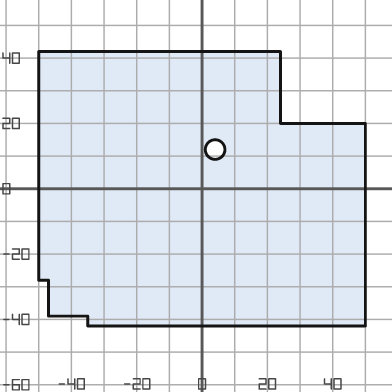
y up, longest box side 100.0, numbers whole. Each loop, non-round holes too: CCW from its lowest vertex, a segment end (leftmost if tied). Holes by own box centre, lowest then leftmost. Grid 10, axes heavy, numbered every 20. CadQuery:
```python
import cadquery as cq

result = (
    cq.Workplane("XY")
    .moveTo(-35.0, -42.0)
    .lineTo(50.0, -42.0)
    .lineTo(50.0, 20.0)
    .lineTo(24.0, 20.0)
    .lineTo(24.0, 42.0)
    .lineTo(-50.0, 42.0)
    .lineTo(-50.0, -28.0)
    .lineTo(-47.0, -28.0)
    .lineTo(-47.0, -39.0)
    .lineTo(-35.0, -39.0)
    .close()
    .moveTo(4.0, 12.0)
    .circle(3.0)
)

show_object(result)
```